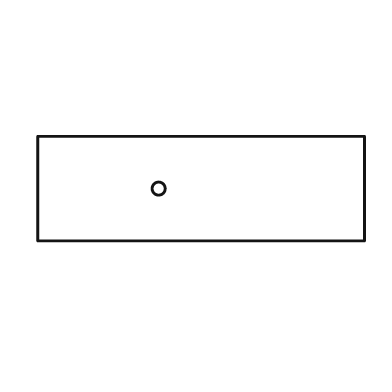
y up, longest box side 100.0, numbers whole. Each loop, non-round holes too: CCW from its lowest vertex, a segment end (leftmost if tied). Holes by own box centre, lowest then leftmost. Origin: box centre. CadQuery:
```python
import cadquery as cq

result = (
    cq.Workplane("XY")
    .moveTo(-50.0, -16.0)
    .lineTo(50.0, -16.0)
    .lineTo(50.0, 16.0)
    .lineTo(-50.0, 16.0)
    .close()
    .moveTo(-13.0, 0.0)
    .circle(2.0)
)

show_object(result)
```